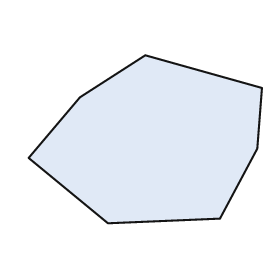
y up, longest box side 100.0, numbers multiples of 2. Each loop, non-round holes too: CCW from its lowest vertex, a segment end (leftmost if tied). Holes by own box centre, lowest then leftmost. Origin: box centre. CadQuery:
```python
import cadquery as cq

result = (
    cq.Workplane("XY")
    .moveTo(-16.0, -36.0)
    .lineTo(32.0, -34.0)
    .lineTo(48.0, -4.0)
    .lineTo(50.0, 22.0)
    .lineTo(0.0, 36.0)
    .lineTo(-28.0, 18.0)
    .lineTo(-50.0, -8.0)
    .close()
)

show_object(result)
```